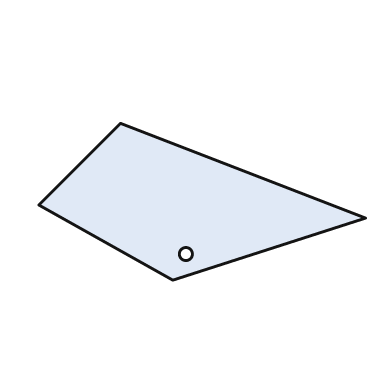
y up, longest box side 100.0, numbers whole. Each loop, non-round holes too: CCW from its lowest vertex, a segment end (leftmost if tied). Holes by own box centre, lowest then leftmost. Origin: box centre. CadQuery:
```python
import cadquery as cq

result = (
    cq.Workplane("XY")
    .moveTo(-9.0, -24.0)
    .lineTo(50.0, -5.0)
    .lineTo(-25.0, 24.0)
    .lineTo(-50.0, -1.0)
    .close()
    .moveTo(-5.0, -16.0)
    .circle(2.0)
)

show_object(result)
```